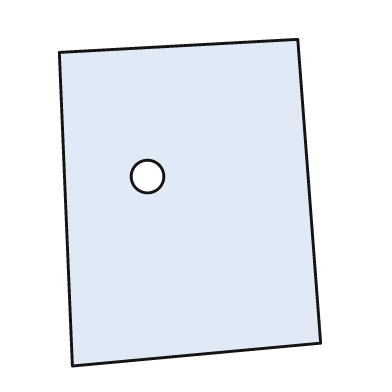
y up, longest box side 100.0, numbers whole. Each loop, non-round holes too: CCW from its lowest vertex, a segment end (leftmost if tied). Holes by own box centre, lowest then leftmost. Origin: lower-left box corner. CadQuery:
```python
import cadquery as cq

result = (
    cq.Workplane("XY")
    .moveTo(4.0, 0.0)
    .lineTo(80.0, 7.0)
    .lineTo(73.0, 100.0)
    .lineTo(0.0, 96.0)
    .close()
    .moveTo(27.0, 58.0)
    .circle(5.0)
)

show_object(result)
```